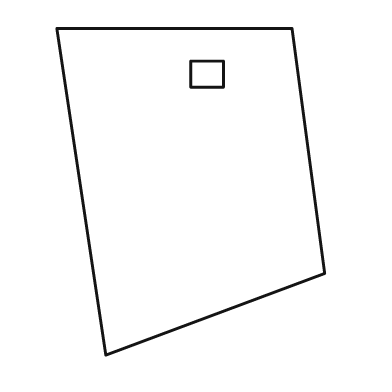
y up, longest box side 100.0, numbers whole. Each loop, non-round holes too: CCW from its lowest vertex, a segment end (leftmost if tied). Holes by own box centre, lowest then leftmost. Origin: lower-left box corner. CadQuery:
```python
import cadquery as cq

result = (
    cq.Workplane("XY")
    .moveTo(15.0, 0.0)
    .lineTo(82.0, 25.0)
    .lineTo(72.0, 100.0)
    .lineTo(0.0, 100.0)
    .close()
    .moveTo(41.0, 82.0)
    .lineTo(51.0, 82.0)
    .lineTo(51.0, 90.0)
    .lineTo(41.0, 90.0)
    .close()
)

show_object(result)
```